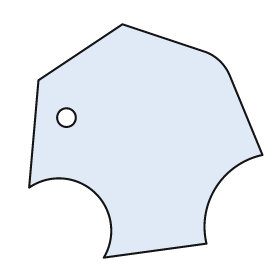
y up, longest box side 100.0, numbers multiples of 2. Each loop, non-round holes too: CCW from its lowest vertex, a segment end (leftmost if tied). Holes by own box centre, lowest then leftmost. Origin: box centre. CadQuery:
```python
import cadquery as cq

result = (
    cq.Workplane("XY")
    .moveTo(-18.0, -50.0)
    .lineTo(26.0, -44.0)
    .threePointArc((30.0, -20.0), (50.0, -6.0))
    .lineTo(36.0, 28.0)
    .threePointArc((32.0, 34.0), (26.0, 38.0))
    .lineTo(-10.0, 50.0)
    .lineTo(-46.0, 26.0)
    .lineTo(-50.0, -20.0)
    .threePointArc((-22.0, -22.0), (-18.0, -50.0))
    .close()
    .moveTo(-34.0, 10.0)
    .circle(4.0)
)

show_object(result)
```